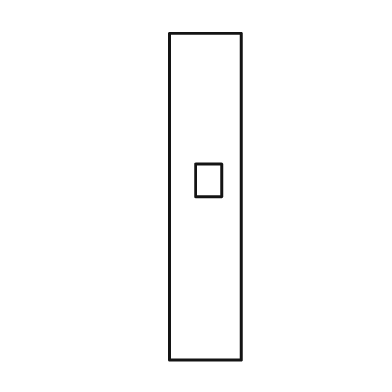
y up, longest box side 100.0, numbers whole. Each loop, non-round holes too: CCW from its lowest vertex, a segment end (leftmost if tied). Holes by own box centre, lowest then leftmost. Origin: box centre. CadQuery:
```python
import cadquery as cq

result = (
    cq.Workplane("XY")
    .moveTo(-11.0, -50.0)
    .lineTo(11.0, -50.0)
    .lineTo(11.0, 50.0)
    .lineTo(-11.0, 50.0)
    .close()
    .moveTo(-3.0, 0.0)
    .lineTo(5.0, 0.0)
    .lineTo(5.0, 10.0)
    .lineTo(-3.0, 10.0)
    .close()
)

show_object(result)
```